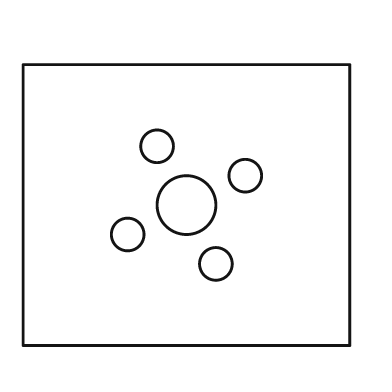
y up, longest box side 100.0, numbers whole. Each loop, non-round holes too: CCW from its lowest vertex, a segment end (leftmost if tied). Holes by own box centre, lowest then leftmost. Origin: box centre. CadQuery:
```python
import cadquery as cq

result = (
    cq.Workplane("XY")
    .moveTo(-50.0, -43.0)
    .lineTo(50.0, -43.0)
    .lineTo(50.0, 43.0)
    .lineTo(-50.0, 43.0)
    .close()
    .moveTo(9.0, -18.0)
    .circle(5.0)
    .moveTo(-18.0, -9.0)
    .circle(5.0)
    .moveTo(0.0, 0.0)
    .circle(9.0)
    .moveTo(18.0, 9.0)
    .circle(5.0)
    .moveTo(-9.0, 18.0)
    .circle(5.0)
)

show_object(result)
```